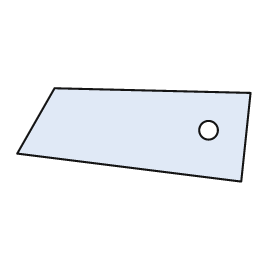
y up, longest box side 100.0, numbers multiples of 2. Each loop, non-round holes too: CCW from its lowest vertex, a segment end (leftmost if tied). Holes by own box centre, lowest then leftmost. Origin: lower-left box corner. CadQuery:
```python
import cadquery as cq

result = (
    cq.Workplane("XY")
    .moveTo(96.0, 0.0)
    .lineTo(100.0, 38.0)
    .lineTo(16.0, 40.0)
    .lineTo(0.0, 12.0)
    .close()
    .moveTo(82.0, 22.0)
    .circle(4.0)
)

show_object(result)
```